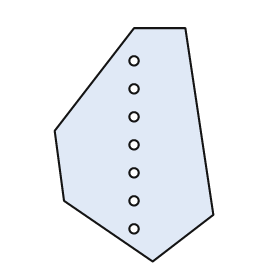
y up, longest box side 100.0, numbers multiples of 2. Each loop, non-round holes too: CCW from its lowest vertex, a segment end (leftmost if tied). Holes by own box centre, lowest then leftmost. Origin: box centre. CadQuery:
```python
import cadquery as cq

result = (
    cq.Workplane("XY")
    .moveTo(8.0, -50.0)
    .lineTo(34.0, -30.0)
    .lineTo(22.0, 50.0)
    .lineTo(0.0, 50.0)
    .lineTo(-34.0, 6.0)
    .lineTo(-30.0, -24.0)
    .close()
    .moveTo(0.0, -36.0)
    .circle(2.0)
    .moveTo(0.0, -24.0)
    .circle(2.0)
    .moveTo(0.0, -12.0)
    .circle(2.0)
    .moveTo(0.0, 0.0)
    .circle(2.0)
    .moveTo(0.0, 12.0)
    .circle(2.0)
    .moveTo(0.0, 24.0)
    .circle(2.0)
    .moveTo(0.0, 36.0)
    .circle(2.0)
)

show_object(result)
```